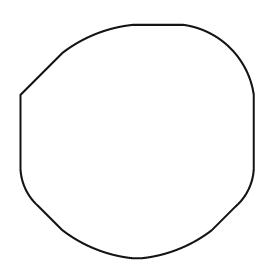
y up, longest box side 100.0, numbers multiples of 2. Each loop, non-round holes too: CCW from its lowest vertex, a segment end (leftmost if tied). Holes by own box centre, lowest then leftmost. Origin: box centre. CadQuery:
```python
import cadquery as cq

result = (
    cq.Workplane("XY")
    .moveTo(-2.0, -50.0)
    .lineTo(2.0, -50.0)
    .threePointArc((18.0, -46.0), (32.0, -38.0))
    .lineTo(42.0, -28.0)
    .threePointArc((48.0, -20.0), (50.0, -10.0))
    .lineTo(50.0, 20.0)
    .threePointArc((40.0, 40.0), (20.0, 50.0))
    .lineTo(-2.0, 50.0)
    .threePointArc((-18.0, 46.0), (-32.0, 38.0))
    .lineTo(-50.0, 20.0)
    .lineTo(-50.0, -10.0)
    .threePointArc((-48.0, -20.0), (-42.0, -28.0))
    .lineTo(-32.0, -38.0)
    .threePointArc((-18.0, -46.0), (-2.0, -50.0))
    .close()
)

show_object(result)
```